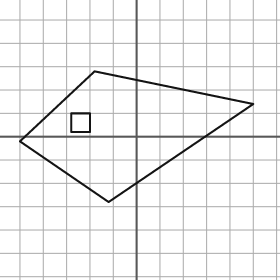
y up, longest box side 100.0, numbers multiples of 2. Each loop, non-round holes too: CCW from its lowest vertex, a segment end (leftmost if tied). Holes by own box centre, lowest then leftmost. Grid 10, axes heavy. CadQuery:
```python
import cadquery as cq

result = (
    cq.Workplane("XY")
    .moveTo(-12.0, -28.0)
    .lineTo(50.0, 14.0)
    .lineTo(-18.0, 28.0)
    .lineTo(-50.0, -2.0)
    .close()
    .moveTo(-28.0, 2.0)
    .lineTo(-20.0, 2.0)
    .lineTo(-20.0, 10.0)
    .lineTo(-28.0, 10.0)
    .close()
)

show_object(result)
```